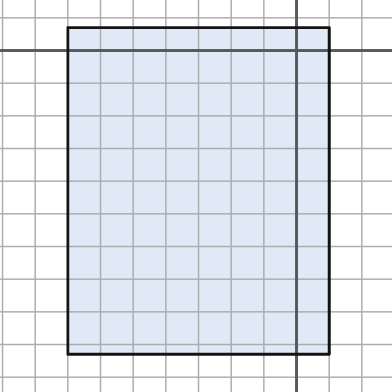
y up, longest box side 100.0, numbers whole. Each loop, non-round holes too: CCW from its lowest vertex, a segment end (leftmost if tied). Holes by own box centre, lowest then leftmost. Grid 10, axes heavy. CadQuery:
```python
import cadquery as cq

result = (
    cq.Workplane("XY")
    .moveTo(-70.0, -93.0)
    .lineTo(10.0, -93.0)
    .lineTo(10.0, 7.0)
    .lineTo(-70.0, 7.0)
    .close()
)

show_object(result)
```